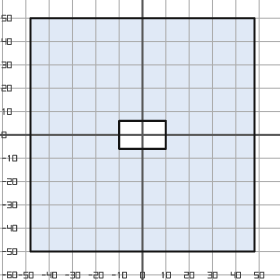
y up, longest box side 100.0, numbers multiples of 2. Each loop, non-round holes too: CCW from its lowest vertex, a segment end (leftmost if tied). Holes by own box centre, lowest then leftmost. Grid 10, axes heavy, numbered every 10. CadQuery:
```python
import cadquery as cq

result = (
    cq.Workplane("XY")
    .moveTo(-48.0, -50.0)
    .lineTo(48.0, -50.0)
    .lineTo(48.0, 50.0)
    .lineTo(-48.0, 50.0)
    .close()
    .moveTo(-10.0, -6.0)
    .lineTo(10.0, -6.0)
    .lineTo(10.0, 6.0)
    .lineTo(-10.0, 6.0)
    .close()
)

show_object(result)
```